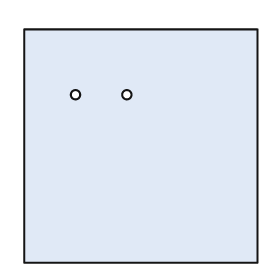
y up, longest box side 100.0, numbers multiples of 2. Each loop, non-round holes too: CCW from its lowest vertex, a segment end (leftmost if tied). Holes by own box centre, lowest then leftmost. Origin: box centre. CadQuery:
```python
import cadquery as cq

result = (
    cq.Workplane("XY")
    .moveTo(-50.0, -50.0)
    .lineTo(50.0, -50.0)
    .lineTo(50.0, 50.0)
    .lineTo(-50.0, 50.0)
    .close()
    .moveTo(-28.0, 22.0)
    .circle(2.0)
    .moveTo(-6.0, 22.0)
    .circle(2.0)
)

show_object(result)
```